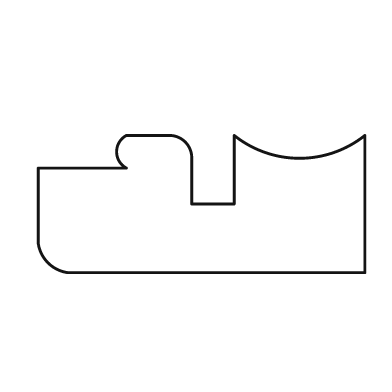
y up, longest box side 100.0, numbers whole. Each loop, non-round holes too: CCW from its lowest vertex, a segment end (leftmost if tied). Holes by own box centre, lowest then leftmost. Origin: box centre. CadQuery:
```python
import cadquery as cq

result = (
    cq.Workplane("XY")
    .moveTo(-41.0, -21.0)
    .lineTo(50.0, -21.0)
    .lineTo(50.0, 21.0)
    .threePointArc((30.0, 14.0), (10.0, 21.0))
    .lineTo(10.0, 0.0)
    .lineTo(-3.0, 0.0)
    .lineTo(-3.0, 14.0)
    .threePointArc((-5.0, 19.0), (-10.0, 21.0))
    .lineTo(-23.0, 21.0)
    .threePointArc((-26.0, 16.0), (-23.0, 11.0))
    .lineTo(-50.0, 11.0)
    .lineTo(-50.0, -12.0)
    .threePointArc((-47.0, -18.0), (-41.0, -21.0))
    .close()
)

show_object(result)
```